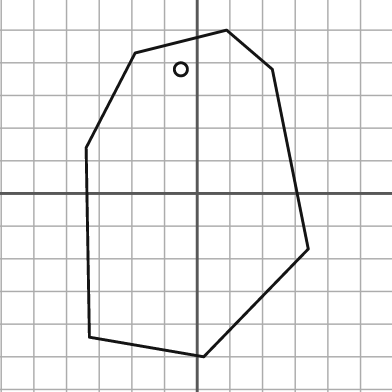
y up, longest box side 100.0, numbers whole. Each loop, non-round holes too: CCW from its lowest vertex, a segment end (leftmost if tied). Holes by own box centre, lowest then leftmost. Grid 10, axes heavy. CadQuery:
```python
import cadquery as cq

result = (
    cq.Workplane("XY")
    .moveTo(2.0, -50.0)
    .lineTo(34.0, -17.0)
    .lineTo(23.0, 38.0)
    .lineTo(9.0, 50.0)
    .lineTo(-19.0, 43.0)
    .lineTo(-34.0, 14.0)
    .lineTo(-33.0, -44.0)
    .close()
    .moveTo(-5.0, 38.0)
    .circle(2.0)
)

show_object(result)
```